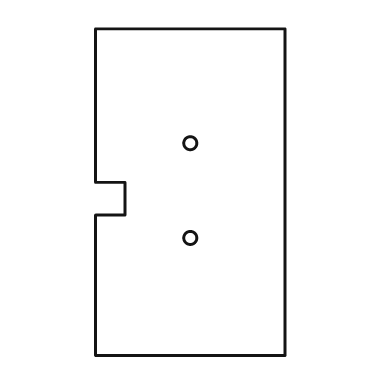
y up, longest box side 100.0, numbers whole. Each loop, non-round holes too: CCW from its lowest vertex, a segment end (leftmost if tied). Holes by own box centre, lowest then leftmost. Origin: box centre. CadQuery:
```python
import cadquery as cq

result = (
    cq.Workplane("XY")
    .moveTo(-29.0, -50.0)
    .lineTo(29.0, -50.0)
    .lineTo(29.0, 50.0)
    .lineTo(-29.0, 50.0)
    .lineTo(-29.0, 3.0)
    .lineTo(-20.0, 3.0)
    .lineTo(-20.0, -7.0)
    .lineTo(-29.0, -7.0)
    .close()
    .moveTo(0.0, -14.0)
    .circle(2.0)
    .moveTo(0.0, 15.0)
    .circle(2.0)
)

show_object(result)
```